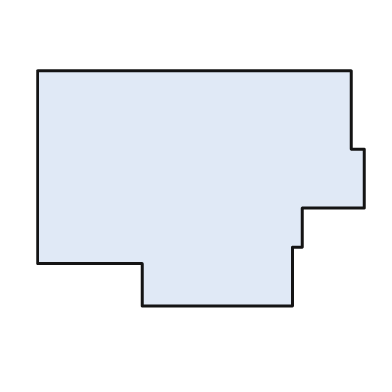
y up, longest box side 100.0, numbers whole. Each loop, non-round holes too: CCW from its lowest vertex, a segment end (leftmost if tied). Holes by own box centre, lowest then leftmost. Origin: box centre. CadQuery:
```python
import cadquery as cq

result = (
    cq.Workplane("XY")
    .moveTo(-18.0, -36.0)
    .lineTo(28.0, -36.0)
    .lineTo(28.0, -18.0)
    .lineTo(31.0, -18.0)
    .lineTo(31.0, -6.0)
    .lineTo(50.0, -6.0)
    .lineTo(50.0, 12.0)
    .lineTo(46.0, 12.0)
    .lineTo(46.0, 36.0)
    .lineTo(-50.0, 36.0)
    .lineTo(-50.0, -23.0)
    .lineTo(-18.0, -23.0)
    .close()
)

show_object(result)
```